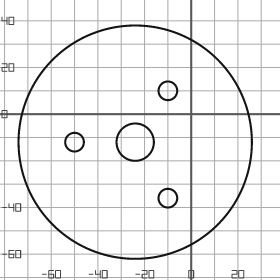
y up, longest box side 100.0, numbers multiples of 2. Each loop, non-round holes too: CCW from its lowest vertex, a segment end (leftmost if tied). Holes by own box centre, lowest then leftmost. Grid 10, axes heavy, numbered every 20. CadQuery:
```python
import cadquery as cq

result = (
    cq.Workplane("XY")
    .moveTo(-24.0, -12.0)
    .circle(50.0)
    .moveTo(-10.0, -36.0)
    .circle(4.0)
    .moveTo(-50.0, -12.0)
    .circle(4.0)
    .moveTo(-24.0, -12.0)
    .circle(8.0)
    .moveTo(-10.0, 10.0)
    .circle(4.0)
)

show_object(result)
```